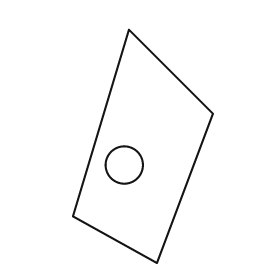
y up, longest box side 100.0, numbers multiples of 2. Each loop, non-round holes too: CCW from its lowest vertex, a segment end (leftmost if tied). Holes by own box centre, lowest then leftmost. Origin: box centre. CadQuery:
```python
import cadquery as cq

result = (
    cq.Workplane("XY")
    .moveTo(6.0, -50.0)
    .lineTo(30.0, 14.0)
    .lineTo(-6.0, 50.0)
    .lineTo(-30.0, -30.0)
    .close()
    .moveTo(-8.0, -8.0)
    .circle(8.0)
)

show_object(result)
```